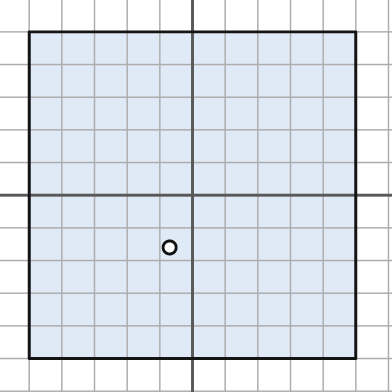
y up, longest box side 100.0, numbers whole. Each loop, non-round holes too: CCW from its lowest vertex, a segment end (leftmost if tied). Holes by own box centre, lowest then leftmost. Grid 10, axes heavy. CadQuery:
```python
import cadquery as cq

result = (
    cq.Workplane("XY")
    .moveTo(-50.0, -50.0)
    .lineTo(50.0, -50.0)
    .lineTo(50.0, 50.0)
    .lineTo(-50.0, 50.0)
    .close()
    .moveTo(-7.0, -16.0)
    .circle(2.0)
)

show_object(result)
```